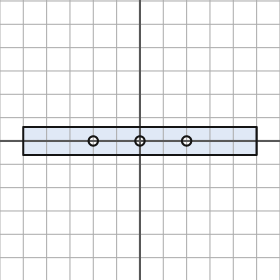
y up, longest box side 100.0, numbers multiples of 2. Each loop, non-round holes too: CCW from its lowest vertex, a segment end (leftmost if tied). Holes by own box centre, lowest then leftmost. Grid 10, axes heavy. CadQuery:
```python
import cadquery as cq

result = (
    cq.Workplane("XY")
    .moveTo(-50.0, -6.0)
    .lineTo(50.0, -6.0)
    .lineTo(50.0, 6.0)
    .lineTo(-50.0, 6.0)
    .close()
    .moveTo(-20.0, 0.0)
    .circle(2.0)
    .moveTo(0.0, 0.0)
    .circle(2.0)
    .moveTo(20.0, 0.0)
    .circle(2.0)
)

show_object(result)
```